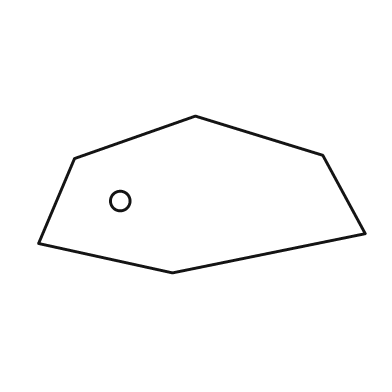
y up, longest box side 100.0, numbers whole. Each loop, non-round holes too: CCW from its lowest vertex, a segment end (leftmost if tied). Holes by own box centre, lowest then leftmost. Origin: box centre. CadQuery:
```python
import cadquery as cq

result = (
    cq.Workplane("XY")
    .moveTo(-9.0, -24.0)
    .lineTo(50.0, -12.0)
    .lineTo(37.0, 12.0)
    .lineTo(-2.0, 24.0)
    .lineTo(-39.0, 11.0)
    .lineTo(-50.0, -15.0)
    .close()
    .moveTo(-25.0, -2.0)
    .circle(3.0)
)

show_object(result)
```